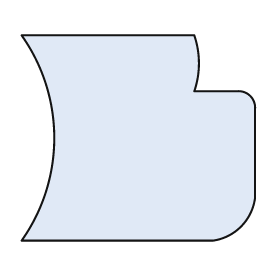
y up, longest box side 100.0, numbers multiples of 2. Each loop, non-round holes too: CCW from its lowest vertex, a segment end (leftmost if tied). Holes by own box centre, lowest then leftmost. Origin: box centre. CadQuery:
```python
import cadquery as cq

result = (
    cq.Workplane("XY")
    .moveTo(-50.0, -44.0)
    .lineTo(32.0, -44.0)
    .threePointArc((44.0, -38.0), (50.0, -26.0))
    .lineTo(50.0, 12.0)
    .threePointArc((48.0, 18.0), (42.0, 20.0))
    .lineTo(24.0, 20.0)
    .threePointArc((26.0, 32.0), (24.0, 44.0))
    .lineTo(-50.0, 44.0)
    .threePointArc((-36.0, 0.0), (-50.0, -44.0))
    .close()
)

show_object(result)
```